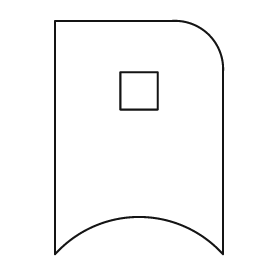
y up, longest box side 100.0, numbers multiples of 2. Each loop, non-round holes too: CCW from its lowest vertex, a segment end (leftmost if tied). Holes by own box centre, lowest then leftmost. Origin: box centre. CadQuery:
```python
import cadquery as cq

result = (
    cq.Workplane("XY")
    .moveTo(-36.0, -50.0)
    .threePointArc((0.0, -34.0), (36.0, -50.0))
    .lineTo(36.0, 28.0)
    .threePointArc((30.0, 44.0), (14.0, 50.0))
    .lineTo(-36.0, 50.0)
    .close()
    .moveTo(-8.0, 12.0)
    .lineTo(8.0, 12.0)
    .lineTo(8.0, 28.0)
    .lineTo(-8.0, 28.0)
    .close()
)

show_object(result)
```